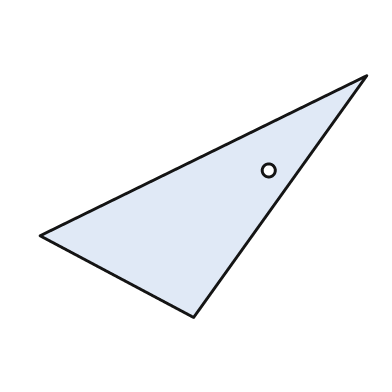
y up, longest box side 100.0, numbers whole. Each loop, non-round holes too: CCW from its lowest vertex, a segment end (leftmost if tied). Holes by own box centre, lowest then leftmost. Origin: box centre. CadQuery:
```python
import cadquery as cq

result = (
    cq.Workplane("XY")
    .moveTo(-3.0, -37.0)
    .lineTo(50.0, 37.0)
    .lineTo(-50.0, -12.0)
    .close()
    .moveTo(20.0, 8.0)
    .circle(2.0)
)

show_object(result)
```